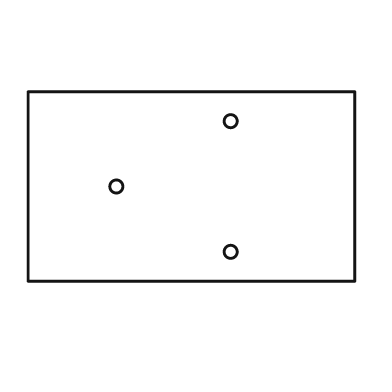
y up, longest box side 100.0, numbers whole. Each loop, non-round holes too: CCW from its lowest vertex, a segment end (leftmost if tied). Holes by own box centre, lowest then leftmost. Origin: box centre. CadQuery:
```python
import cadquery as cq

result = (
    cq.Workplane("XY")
    .moveTo(-50.0, -29.0)
    .lineTo(50.0, -29.0)
    .lineTo(50.0, 29.0)
    .lineTo(-50.0, 29.0)
    .close()
    .moveTo(12.0, -20.0)
    .circle(2.0)
    .moveTo(-23.0, 0.0)
    .circle(2.0)
    .moveTo(12.0, 20.0)
    .circle(2.0)
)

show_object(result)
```